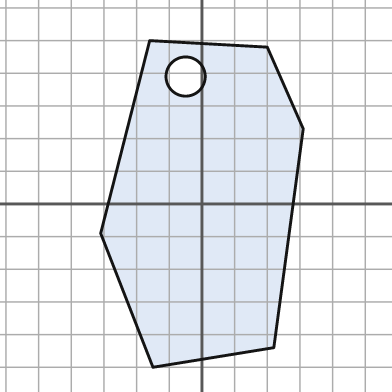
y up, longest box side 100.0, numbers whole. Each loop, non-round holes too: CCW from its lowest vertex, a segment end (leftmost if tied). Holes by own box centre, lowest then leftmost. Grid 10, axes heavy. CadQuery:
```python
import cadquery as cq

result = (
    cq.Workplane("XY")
    .moveTo(-15.0, -50.0)
    .lineTo(22.0, -44.0)
    .lineTo(31.0, 23.0)
    .lineTo(20.0, 48.0)
    .lineTo(-16.0, 50.0)
    .lineTo(-31.0, -9.0)
    .close()
    .moveTo(-5.0, 39.0)
    .circle(6.0)
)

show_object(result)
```